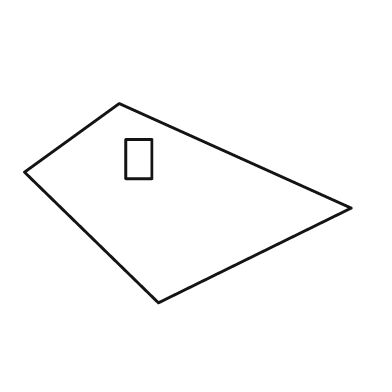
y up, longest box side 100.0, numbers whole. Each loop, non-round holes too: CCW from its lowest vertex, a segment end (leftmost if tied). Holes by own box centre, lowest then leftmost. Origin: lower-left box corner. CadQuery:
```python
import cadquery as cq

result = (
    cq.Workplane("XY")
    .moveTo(41.0, 0.0)
    .lineTo(100.0, 29.0)
    .lineTo(29.0, 61.0)
    .lineTo(0.0, 40.0)
    .close()
    .moveTo(31.0, 38.0)
    .lineTo(39.0, 38.0)
    .lineTo(39.0, 50.0)
    .lineTo(31.0, 50.0)
    .close()
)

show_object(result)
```